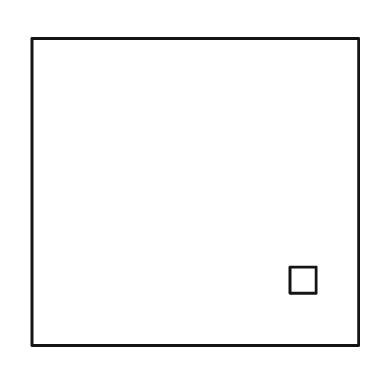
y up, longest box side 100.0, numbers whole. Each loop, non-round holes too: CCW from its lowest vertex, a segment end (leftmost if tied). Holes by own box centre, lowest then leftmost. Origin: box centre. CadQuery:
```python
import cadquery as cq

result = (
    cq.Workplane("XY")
    .moveTo(-50.0, -47.0)
    .lineTo(50.0, -47.0)
    .lineTo(50.0, 47.0)
    .lineTo(-50.0, 47.0)
    .close()
    .moveTo(29.0, -31.0)
    .lineTo(37.0, -31.0)
    .lineTo(37.0, -23.0)
    .lineTo(29.0, -23.0)
    .close()
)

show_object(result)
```